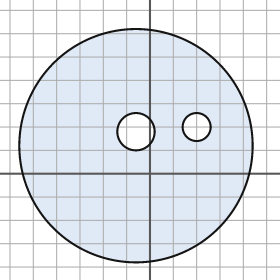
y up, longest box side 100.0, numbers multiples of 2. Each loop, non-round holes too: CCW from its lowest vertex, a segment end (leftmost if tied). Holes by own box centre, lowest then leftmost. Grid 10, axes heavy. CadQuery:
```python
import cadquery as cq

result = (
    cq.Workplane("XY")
    .moveTo(-6.0, 12.0)
    .circle(50.0)
    .moveTo(-6.0, 18.0)
    .circle(8.0)
    .moveTo(20.0, 20.0)
    .circle(6.0)
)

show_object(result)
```